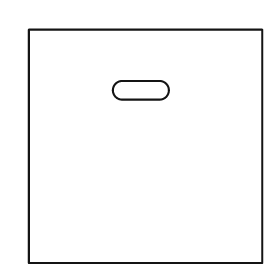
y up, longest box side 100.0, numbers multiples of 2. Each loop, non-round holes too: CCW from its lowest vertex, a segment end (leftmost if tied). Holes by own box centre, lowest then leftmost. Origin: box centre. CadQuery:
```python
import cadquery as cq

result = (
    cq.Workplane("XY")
    .moveTo(-50.0, -50.0)
    .lineTo(50.0, -50.0)
    .lineTo(50.0, 50.0)
    .lineTo(-50.0, 50.0)
    .close()
    .moveTo(-10.0, 20.0)
    .lineTo(6.0, 20.0)
    .threePointArc((10.0, 24.0), (6.0, 28.0))
    .lineTo(-10.0, 28.0)
    .threePointArc((-14.0, 24.0), (-10.0, 20.0))
    .close()
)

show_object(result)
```